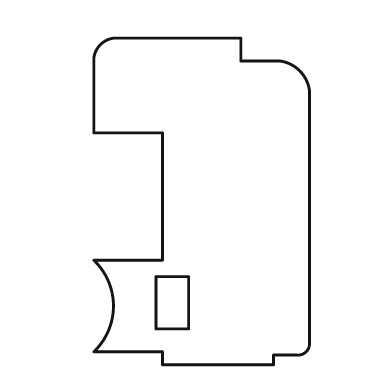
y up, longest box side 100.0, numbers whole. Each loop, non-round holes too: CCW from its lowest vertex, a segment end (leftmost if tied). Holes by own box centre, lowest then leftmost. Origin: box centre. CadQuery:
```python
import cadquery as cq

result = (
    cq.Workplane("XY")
    .moveTo(-12.0, -50.0)
    .lineTo(22.0, -50.0)
    .lineTo(22.0, -47.0)
    .lineTo(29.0, -47.0)
    .threePointArc((32.0, -46.0), (33.0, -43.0))
    .lineTo(33.0, 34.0)
    .threePointArc((30.0, 40.0), (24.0, 43.0))
    .lineTo(12.0, 43.0)
    .lineTo(12.0, 50.0)
    .lineTo(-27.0, 50.0)
    .threePointArc((-31.0, 48.0), (-33.0, 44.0))
    .lineTo(-33.0, 21.0)
    .lineTo(-12.0, 21.0)
    .lineTo(-12.0, -18.0)
    .lineTo(-33.0, -18.0)
    .threePointArc((-27.0, -32.0), (-33.0, -46.0))
    .lineTo(-12.0, -46.0)
    .close()
    .moveTo(-14.0, -39.0)
    .lineTo(-4.0, -39.0)
    .lineTo(-4.0, -23.0)
    .lineTo(-14.0, -23.0)
    .close()
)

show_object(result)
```